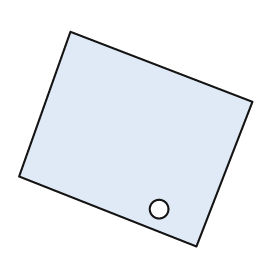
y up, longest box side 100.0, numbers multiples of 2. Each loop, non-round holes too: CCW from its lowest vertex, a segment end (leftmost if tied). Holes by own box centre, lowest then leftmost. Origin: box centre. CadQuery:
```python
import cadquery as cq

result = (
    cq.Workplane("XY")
    .moveTo(26.0, -46.0)
    .lineTo(50.0, 16.0)
    .lineTo(-28.0, 46.0)
    .lineTo(-50.0, -16.0)
    .close()
    .moveTo(10.0, -30.0)
    .circle(4.0)
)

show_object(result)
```